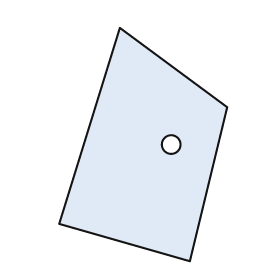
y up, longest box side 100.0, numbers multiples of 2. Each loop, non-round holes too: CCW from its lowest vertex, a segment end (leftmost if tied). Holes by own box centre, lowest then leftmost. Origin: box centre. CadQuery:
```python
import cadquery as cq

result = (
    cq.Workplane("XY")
    .moveTo(20.0, -50.0)
    .lineTo(36.0, 16.0)
    .lineTo(-10.0, 50.0)
    .lineTo(-36.0, -34.0)
    .close()
    .moveTo(12.0, 0.0)
    .circle(4.0)
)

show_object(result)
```